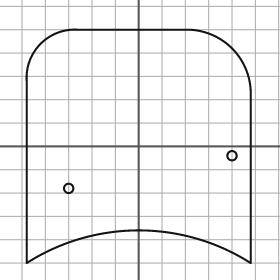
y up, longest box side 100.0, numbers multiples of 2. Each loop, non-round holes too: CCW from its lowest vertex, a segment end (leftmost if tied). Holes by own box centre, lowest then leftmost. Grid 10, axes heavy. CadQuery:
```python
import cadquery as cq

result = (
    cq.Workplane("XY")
    .moveTo(-48.0, -50.0)
    .threePointArc((0.0, -36.0), (48.0, -50.0))
    .lineTo(48.0, 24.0)
    .threePointArc((40.0, 42.0), (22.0, 50.0))
    .lineTo(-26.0, 50.0)
    .threePointArc((-42.0, 44.0), (-48.0, 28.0))
    .close()
    .moveTo(-30.0, -18.0)
    .circle(2.0)
    .moveTo(40.0, -4.0)
    .circle(2.0)
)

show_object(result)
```